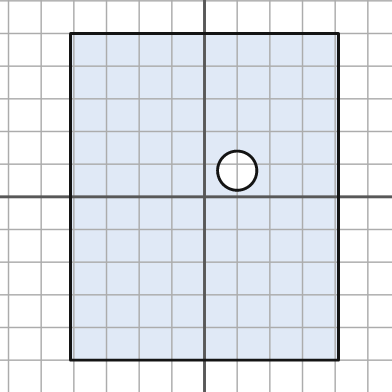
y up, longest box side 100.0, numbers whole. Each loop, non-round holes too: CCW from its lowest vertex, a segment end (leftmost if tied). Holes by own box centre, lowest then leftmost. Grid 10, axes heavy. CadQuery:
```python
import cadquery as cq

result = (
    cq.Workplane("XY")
    .moveTo(-41.0, -50.0)
    .lineTo(41.0, -50.0)
    .lineTo(41.0, 50.0)
    .lineTo(-41.0, 50.0)
    .close()
    .moveTo(10.0, 8.0)
    .circle(6.0)
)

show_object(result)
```